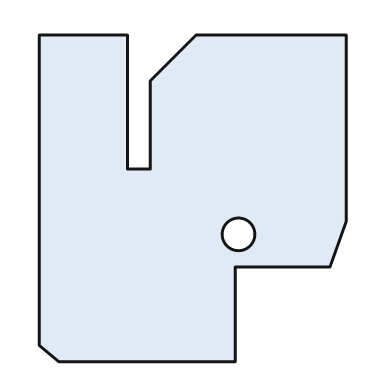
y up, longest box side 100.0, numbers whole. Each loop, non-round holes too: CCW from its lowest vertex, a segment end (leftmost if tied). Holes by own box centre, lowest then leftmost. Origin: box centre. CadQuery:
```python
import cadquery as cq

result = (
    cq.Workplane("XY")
    .moveTo(-41.0, -50.0)
    .lineTo(13.0, -50.0)
    .lineTo(13.0, -21.0)
    .lineTo(42.0, -21.0)
    .lineTo(47.0, -7.0)
    .lineTo(47.0, 50.0)
    .lineTo(1.0, 50.0)
    .lineTo(-13.0, 36.0)
    .lineTo(-13.0, 9.0)
    .lineTo(-20.0, 9.0)
    .lineTo(-20.0, 50.0)
    .lineTo(-47.0, 50.0)
    .lineTo(-47.0, -45.0)
    .close()
    .moveTo(14.0, -11.0)
    .circle(5.0)
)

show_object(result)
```